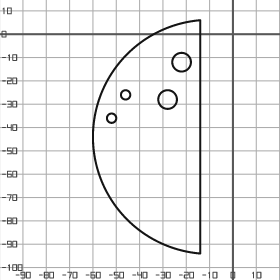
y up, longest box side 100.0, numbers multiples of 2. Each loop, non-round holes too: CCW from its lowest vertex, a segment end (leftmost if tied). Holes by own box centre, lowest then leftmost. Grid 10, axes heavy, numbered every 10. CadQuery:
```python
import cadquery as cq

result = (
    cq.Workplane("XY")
    .moveTo(-14.0, -94.0)
    .lineTo(-14.0, 6.0)
    .threePointArc((-60.0, -44.0), (-14.0, -94.0))
    .close()
    .moveTo(-52.0, -36.0)
    .circle(2.0)
    .moveTo(-28.0, -28.0)
    .circle(4.0)
    .moveTo(-46.0, -26.0)
    .circle(2.0)
    .moveTo(-22.0, -12.0)
    .circle(4.0)
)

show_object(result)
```